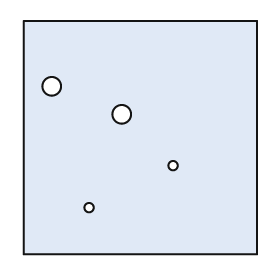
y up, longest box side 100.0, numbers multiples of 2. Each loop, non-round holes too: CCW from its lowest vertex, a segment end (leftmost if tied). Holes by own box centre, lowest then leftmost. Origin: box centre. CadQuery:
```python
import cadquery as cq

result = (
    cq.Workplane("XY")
    .moveTo(-50.0, -50.0)
    .lineTo(50.0, -50.0)
    .lineTo(50.0, 50.0)
    .lineTo(-50.0, 50.0)
    .close()
    .moveTo(-22.0, -30.0)
    .circle(2.0)
    .moveTo(14.0, -12.0)
    .circle(2.0)
    .moveTo(-8.0, 10.0)
    .circle(4.0)
    .moveTo(-38.0, 22.0)
    .circle(4.0)
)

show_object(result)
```